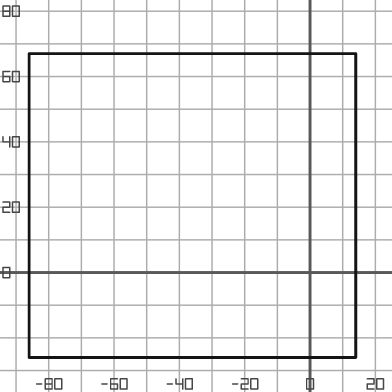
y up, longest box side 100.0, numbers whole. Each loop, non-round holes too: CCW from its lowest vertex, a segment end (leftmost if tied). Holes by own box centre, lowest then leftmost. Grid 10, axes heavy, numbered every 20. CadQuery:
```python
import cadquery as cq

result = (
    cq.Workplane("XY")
    .moveTo(-86.0, -26.0)
    .lineTo(14.0, -26.0)
    .lineTo(14.0, 67.0)
    .lineTo(-86.0, 67.0)
    .close()
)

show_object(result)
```